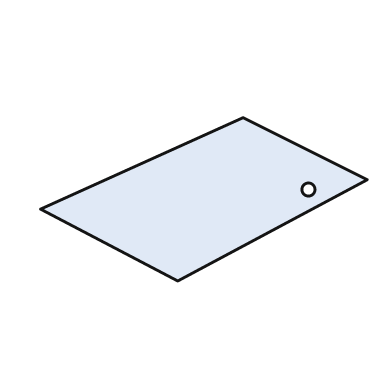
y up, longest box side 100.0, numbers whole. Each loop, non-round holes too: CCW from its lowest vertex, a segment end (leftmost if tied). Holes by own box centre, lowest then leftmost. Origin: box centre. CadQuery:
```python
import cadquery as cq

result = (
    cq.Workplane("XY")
    .moveTo(-8.0, -25.0)
    .lineTo(50.0, 6.0)
    .lineTo(12.0, 25.0)
    .lineTo(-50.0, -3.0)
    .close()
    .moveTo(32.0, 3.0)
    .circle(2.0)
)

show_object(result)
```